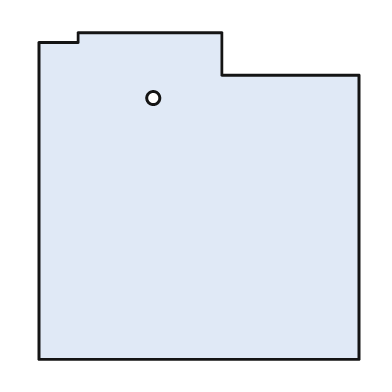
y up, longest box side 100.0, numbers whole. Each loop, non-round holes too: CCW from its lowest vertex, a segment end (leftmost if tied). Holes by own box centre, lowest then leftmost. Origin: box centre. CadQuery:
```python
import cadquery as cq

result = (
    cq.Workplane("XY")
    .moveTo(-49.0, -50.0)
    .lineTo(49.0, -50.0)
    .lineTo(49.0, 37.0)
    .lineTo(7.0, 37.0)
    .lineTo(7.0, 50.0)
    .lineTo(-37.0, 50.0)
    .lineTo(-37.0, 47.0)
    .lineTo(-49.0, 47.0)
    .close()
    .moveTo(-14.0, 30.0)
    .circle(2.0)
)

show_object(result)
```